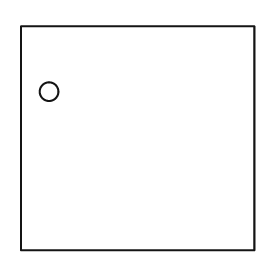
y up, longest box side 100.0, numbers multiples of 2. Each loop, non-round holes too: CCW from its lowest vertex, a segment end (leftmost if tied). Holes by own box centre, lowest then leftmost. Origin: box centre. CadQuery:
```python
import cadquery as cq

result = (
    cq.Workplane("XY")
    .moveTo(-50.0, -48.0)
    .lineTo(50.0, -48.0)
    .lineTo(50.0, 48.0)
    .lineTo(-50.0, 48.0)
    .close()
    .moveTo(-38.0, 20.0)
    .circle(4.0)
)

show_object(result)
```